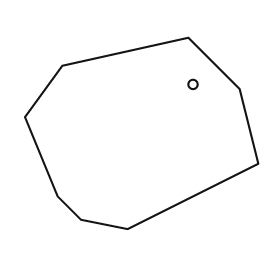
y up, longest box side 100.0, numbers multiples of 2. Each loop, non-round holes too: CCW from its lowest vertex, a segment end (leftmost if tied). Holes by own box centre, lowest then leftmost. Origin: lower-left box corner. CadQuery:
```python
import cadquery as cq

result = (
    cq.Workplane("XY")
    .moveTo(44.0, 0.0)
    .lineTo(100.0, 28.0)
    .lineTo(92.0, 60.0)
    .lineTo(70.0, 82.0)
    .lineTo(16.0, 70.0)
    .lineTo(0.0, 48.0)
    .lineTo(14.0, 14.0)
    .lineTo(24.0, 4.0)
    .close()
    .moveTo(72.0, 62.0)
    .circle(2.0)
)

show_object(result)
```